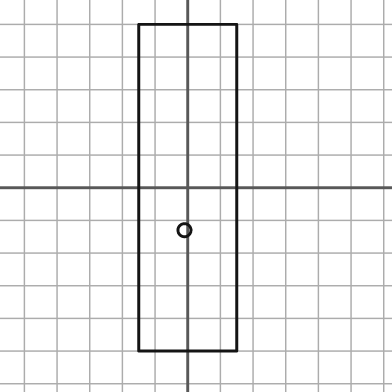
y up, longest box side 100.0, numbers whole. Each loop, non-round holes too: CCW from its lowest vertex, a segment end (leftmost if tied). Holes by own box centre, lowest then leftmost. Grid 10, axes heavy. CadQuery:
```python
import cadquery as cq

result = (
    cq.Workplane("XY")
    .moveTo(-15.0, -50.0)
    .lineTo(15.0, -50.0)
    .lineTo(15.0, 50.0)
    .lineTo(-15.0, 50.0)
    .close()
    .moveTo(-1.0, -13.0)
    .circle(2.0)
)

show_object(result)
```